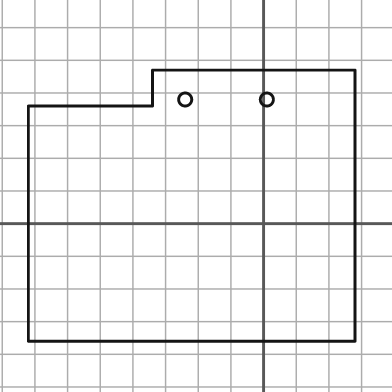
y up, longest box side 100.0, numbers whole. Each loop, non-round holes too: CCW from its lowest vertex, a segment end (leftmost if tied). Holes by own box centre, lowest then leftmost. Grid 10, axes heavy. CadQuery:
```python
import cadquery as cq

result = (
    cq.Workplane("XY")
    .moveTo(-72.0, -36.0)
    .lineTo(28.0, -36.0)
    .lineTo(28.0, 47.0)
    .lineTo(-34.0, 47.0)
    .lineTo(-34.0, 36.0)
    .lineTo(-72.0, 36.0)
    .close()
    .moveTo(-24.0, 38.0)
    .circle(2.0)
    .moveTo(1.0, 38.0)
    .circle(2.0)
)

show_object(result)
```